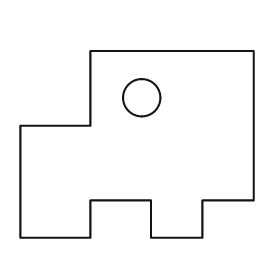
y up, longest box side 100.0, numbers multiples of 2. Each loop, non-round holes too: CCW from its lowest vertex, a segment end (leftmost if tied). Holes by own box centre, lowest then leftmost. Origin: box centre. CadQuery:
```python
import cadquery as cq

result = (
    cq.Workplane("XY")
    .moveTo(-50.0, -40.0)
    .lineTo(-20.0, -40.0)
    .lineTo(-20.0, -24.0)
    .lineTo(6.0, -24.0)
    .lineTo(6.0, -40.0)
    .lineTo(28.0, -40.0)
    .lineTo(28.0, -24.0)
    .lineTo(50.0, -24.0)
    .lineTo(50.0, 40.0)
    .lineTo(-20.0, 40.0)
    .lineTo(-20.0, 8.0)
    .lineTo(-50.0, 8.0)
    .close()
    .moveTo(2.0, 20.0)
    .circle(8.0)
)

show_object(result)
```